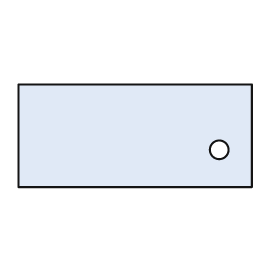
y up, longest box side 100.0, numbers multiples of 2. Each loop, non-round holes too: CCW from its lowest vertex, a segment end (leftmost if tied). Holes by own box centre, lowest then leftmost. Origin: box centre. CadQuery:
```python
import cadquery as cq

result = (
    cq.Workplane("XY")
    .moveTo(-50.0, -22.0)
    .lineTo(50.0, -22.0)
    .lineTo(50.0, 22.0)
    .lineTo(-50.0, 22.0)
    .close()
    .moveTo(36.0, -6.0)
    .circle(4.0)
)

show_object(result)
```